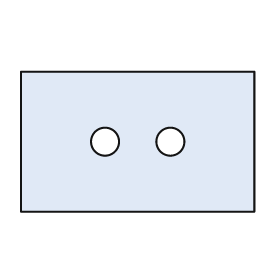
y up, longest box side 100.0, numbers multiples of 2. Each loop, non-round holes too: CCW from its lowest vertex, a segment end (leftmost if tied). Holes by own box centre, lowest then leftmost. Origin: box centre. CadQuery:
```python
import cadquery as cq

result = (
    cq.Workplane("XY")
    .moveTo(-50.0, -30.0)
    .lineTo(50.0, -30.0)
    .lineTo(50.0, 30.0)
    .lineTo(-50.0, 30.0)
    .close()
    .moveTo(-14.0, 0.0)
    .circle(6.0)
    .moveTo(14.0, 0.0)
    .circle(6.0)
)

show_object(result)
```